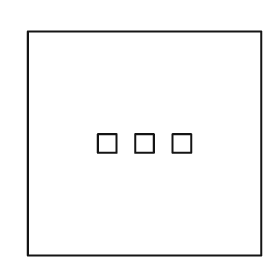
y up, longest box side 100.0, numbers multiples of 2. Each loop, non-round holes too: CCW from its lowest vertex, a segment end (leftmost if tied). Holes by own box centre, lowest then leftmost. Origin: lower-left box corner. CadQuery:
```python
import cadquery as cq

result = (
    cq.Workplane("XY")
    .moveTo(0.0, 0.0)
    .lineTo(100.0, 0.0)
    .lineTo(100.0, 96.0)
    .lineTo(0.0, 96.0)
    .close()
    .moveTo(30.0, 44.0)
    .lineTo(38.0, 44.0)
    .lineTo(38.0, 52.0)
    .lineTo(30.0, 52.0)
    .close()
    .moveTo(46.0, 44.0)
    .lineTo(54.0, 44.0)
    .lineTo(54.0, 52.0)
    .lineTo(46.0, 52.0)
    .close()
    .moveTo(62.0, 44.0)
    .lineTo(70.0, 44.0)
    .lineTo(70.0, 52.0)
    .lineTo(62.0, 52.0)
    .close()
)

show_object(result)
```